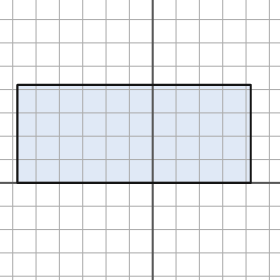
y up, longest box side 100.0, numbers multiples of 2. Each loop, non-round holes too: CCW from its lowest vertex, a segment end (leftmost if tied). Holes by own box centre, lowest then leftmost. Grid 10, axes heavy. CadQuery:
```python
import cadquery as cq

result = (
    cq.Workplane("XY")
    .moveTo(-58.0, 0.0)
    .lineTo(42.0, 0.0)
    .lineTo(42.0, 42.0)
    .lineTo(-58.0, 42.0)
    .close()
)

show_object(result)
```